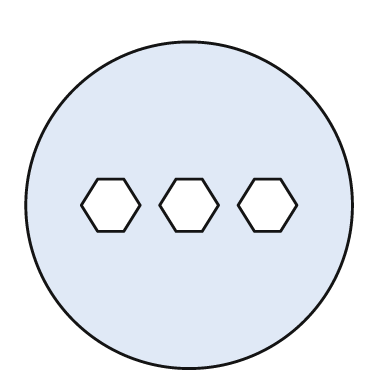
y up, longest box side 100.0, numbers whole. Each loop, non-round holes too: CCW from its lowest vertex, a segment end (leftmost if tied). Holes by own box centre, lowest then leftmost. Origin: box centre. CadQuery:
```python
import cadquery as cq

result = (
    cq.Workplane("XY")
    .moveTo(0.0, 0.0)
    .circle(50.0)
    .moveTo(-28.0, -8.0)
    .lineTo(-20.0, -8.0)
    .lineTo(-15.0, 0.0)
    .lineTo(-20.0, 8.0)
    .lineTo(-28.0, 8.0)
    .lineTo(-33.0, 0.0)
    .close()
    .moveTo(-4.0, -8.0)
    .lineTo(4.0, -8.0)
    .lineTo(9.0, 0.0)
    .lineTo(4.0, 8.0)
    .lineTo(-4.0, 8.0)
    .lineTo(-9.0, 0.0)
    .close()
    .moveTo(20.0, -8.0)
    .lineTo(28.0, -8.0)
    .lineTo(33.0, 0.0)
    .lineTo(28.0, 8.0)
    .lineTo(20.0, 8.0)
    .lineTo(15.0, 0.0)
    .close()
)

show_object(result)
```